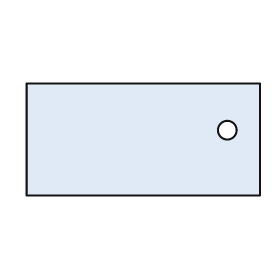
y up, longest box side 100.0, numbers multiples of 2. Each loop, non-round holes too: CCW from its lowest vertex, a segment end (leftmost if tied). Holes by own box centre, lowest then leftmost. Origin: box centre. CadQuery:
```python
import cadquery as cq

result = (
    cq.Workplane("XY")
    .moveTo(-50.0, -24.0)
    .lineTo(50.0, -24.0)
    .lineTo(50.0, 24.0)
    .lineTo(-50.0, 24.0)
    .close()
    .moveTo(36.0, 4.0)
    .circle(4.0)
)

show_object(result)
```